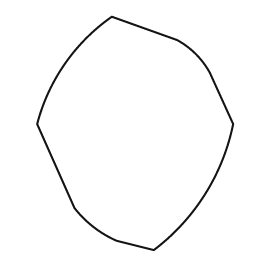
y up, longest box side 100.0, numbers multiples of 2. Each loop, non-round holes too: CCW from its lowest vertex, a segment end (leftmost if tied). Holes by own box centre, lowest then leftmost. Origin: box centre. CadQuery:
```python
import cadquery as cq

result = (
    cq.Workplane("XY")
    .moveTo(8.0, -50.0)
    .threePointArc((30.0, -26.0), (42.0, 4.0))
    .lineTo(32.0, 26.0)
    .threePointArc((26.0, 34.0), (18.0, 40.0))
    .lineTo(-10.0, 50.0)
    .threePointArc((-30.0, 30.0), (-42.0, 4.0))
    .lineTo(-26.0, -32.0)
    .threePointArc((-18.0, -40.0), (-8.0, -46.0))
    .close()
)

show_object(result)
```